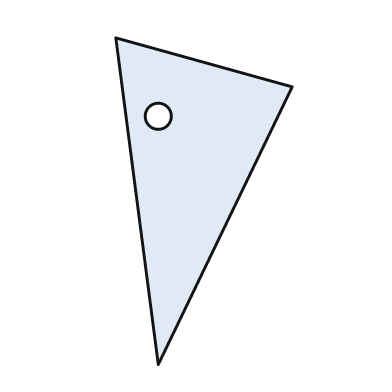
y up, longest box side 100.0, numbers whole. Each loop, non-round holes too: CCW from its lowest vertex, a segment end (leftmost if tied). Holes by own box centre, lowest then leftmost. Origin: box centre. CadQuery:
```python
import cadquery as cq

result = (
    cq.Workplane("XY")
    .moveTo(-14.0, -50.0)
    .lineTo(27.0, 35.0)
    .lineTo(-27.0, 50.0)
    .close()
    .moveTo(-14.0, 26.0)
    .circle(4.0)
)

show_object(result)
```